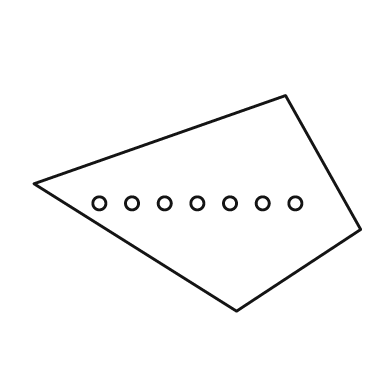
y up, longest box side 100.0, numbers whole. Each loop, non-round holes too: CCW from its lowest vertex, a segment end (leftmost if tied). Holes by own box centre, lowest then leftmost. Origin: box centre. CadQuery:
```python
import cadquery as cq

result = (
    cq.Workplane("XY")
    .moveTo(12.0, -33.0)
    .lineTo(50.0, -8.0)
    .lineTo(27.0, 33.0)
    .lineTo(-50.0, 6.0)
    .close()
    .moveTo(-30.0, 0.0)
    .circle(2.0)
    .moveTo(-20.0, 0.0)
    .circle(2.0)
    .moveTo(-10.0, 0.0)
    .circle(2.0)
    .moveTo(0.0, 0.0)
    .circle(2.0)
    .moveTo(10.0, 0.0)
    .circle(2.0)
    .moveTo(20.0, 0.0)
    .circle(2.0)
    .moveTo(30.0, 0.0)
    .circle(2.0)
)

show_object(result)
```